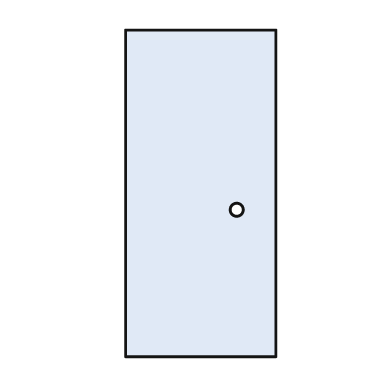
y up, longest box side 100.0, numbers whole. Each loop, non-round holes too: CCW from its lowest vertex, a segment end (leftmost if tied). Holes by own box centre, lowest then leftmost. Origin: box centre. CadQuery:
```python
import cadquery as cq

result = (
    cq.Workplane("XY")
    .moveTo(-23.0, -50.0)
    .lineTo(23.0, -50.0)
    .lineTo(23.0, 50.0)
    .lineTo(-23.0, 50.0)
    .close()
    .moveTo(11.0, -5.0)
    .circle(2.0)
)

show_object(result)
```